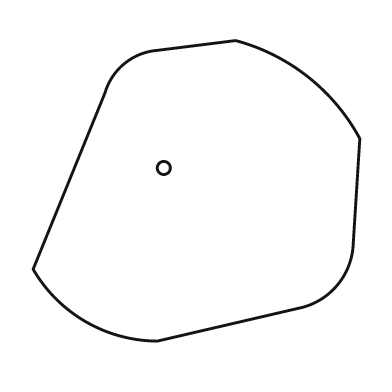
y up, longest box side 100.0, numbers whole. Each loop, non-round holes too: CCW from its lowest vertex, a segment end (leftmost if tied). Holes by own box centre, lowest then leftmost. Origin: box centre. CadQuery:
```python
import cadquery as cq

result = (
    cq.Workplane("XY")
    .moveTo(-12.0, -46.0)
    .lineTo(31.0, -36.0)
    .threePointArc((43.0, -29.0), (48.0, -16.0))
    .lineTo(50.0, 16.0)
    .threePointArc((34.0, 35.0), (12.0, 46.0))
    .lineTo(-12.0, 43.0)
    .threePointArc((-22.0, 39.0), (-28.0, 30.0))
    .lineTo(-50.0, -24.0)
    .threePointArc((-34.0, -40.0), (-12.0, -46.0))
    .close()
    .moveTo(-10.0, 7.0)
    .circle(2.0)
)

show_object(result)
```